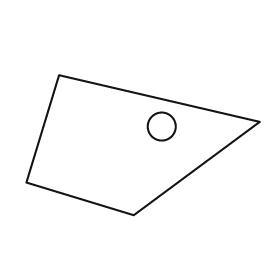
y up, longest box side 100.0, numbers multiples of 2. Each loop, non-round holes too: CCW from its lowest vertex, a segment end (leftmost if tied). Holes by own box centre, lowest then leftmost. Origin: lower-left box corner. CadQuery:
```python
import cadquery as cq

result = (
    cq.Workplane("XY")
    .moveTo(46.0, 0.0)
    .lineTo(100.0, 40.0)
    .lineTo(14.0, 60.0)
    .lineTo(0.0, 14.0)
    .close()
    .moveTo(58.0, 38.0)
    .circle(6.0)
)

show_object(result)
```